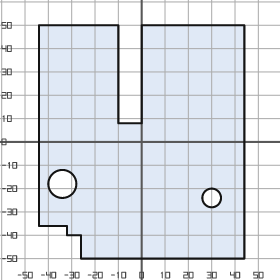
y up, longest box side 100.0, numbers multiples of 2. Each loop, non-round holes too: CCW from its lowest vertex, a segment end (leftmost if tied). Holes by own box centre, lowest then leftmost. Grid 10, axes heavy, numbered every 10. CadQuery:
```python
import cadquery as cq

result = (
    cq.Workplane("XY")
    .moveTo(-26.0, -50.0)
    .lineTo(44.0, -50.0)
    .lineTo(44.0, 50.0)
    .lineTo(0.0, 50.0)
    .lineTo(0.0, 8.0)
    .lineTo(-10.0, 8.0)
    .lineTo(-10.0, 50.0)
    .lineTo(-44.0, 50.0)
    .lineTo(-44.0, -36.0)
    .lineTo(-32.0, -36.0)
    .lineTo(-32.0, -40.0)
    .lineTo(-26.0, -40.0)
    .close()
    .moveTo(30.0, -24.0)
    .circle(4.0)
    .moveTo(-34.0, -18.0)
    .circle(6.0)
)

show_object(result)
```